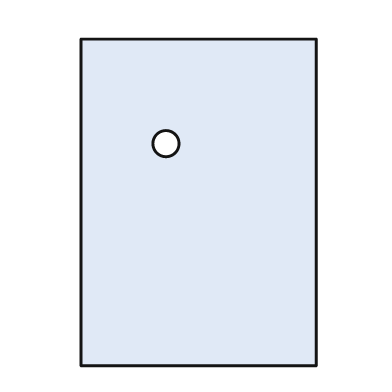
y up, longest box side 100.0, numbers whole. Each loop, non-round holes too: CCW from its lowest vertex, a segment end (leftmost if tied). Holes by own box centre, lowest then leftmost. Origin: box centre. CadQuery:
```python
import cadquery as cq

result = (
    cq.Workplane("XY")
    .moveTo(-36.0, -50.0)
    .lineTo(36.0, -50.0)
    .lineTo(36.0, 50.0)
    .lineTo(-36.0, 50.0)
    .close()
    .moveTo(-10.0, 18.0)
    .circle(4.0)
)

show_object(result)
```